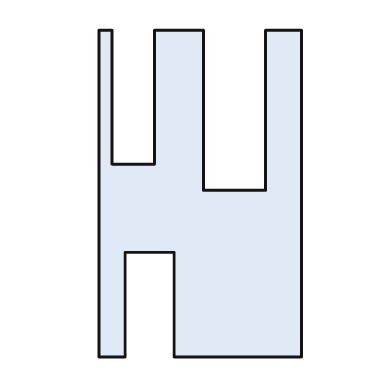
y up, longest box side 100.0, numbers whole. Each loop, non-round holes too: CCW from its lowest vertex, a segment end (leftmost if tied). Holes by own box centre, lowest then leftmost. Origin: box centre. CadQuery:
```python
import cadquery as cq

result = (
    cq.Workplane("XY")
    .moveTo(-31.0, -50.0)
    .lineTo(-23.0, -50.0)
    .lineTo(-23.0, -18.0)
    .lineTo(-8.0, -18.0)
    .lineTo(-8.0, -50.0)
    .lineTo(31.0, -50.0)
    .lineTo(31.0, 50.0)
    .lineTo(20.0, 50.0)
    .lineTo(20.0, 1.0)
    .lineTo(1.0, 1.0)
    .lineTo(1.0, 50.0)
    .lineTo(-14.0, 50.0)
    .lineTo(-14.0, 9.0)
    .lineTo(-27.0, 9.0)
    .lineTo(-27.0, 50.0)
    .lineTo(-31.0, 50.0)
    .close()
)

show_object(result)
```